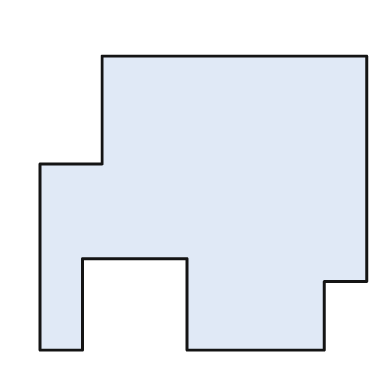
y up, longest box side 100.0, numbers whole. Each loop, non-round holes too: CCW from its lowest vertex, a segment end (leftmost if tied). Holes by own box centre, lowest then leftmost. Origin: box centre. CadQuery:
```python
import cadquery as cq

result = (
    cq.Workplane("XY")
    .moveTo(-50.0, -45.0)
    .lineTo(-37.0, -45.0)
    .lineTo(-37.0, -17.0)
    .lineTo(-5.0, -17.0)
    .lineTo(-5.0, -45.0)
    .lineTo(37.0, -45.0)
    .lineTo(37.0, -24.0)
    .lineTo(50.0, -24.0)
    .lineTo(50.0, 45.0)
    .lineTo(-31.0, 45.0)
    .lineTo(-31.0, 12.0)
    .lineTo(-50.0, 12.0)
    .close()
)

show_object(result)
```